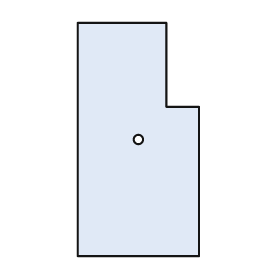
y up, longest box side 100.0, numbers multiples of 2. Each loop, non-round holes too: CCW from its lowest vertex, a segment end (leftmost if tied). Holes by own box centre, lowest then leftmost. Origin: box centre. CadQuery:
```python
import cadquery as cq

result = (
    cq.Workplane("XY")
    .moveTo(-26.0, -50.0)
    .lineTo(26.0, -50.0)
    .lineTo(26.0, 14.0)
    .lineTo(12.0, 14.0)
    .lineTo(12.0, 50.0)
    .lineTo(-26.0, 50.0)
    .close()
    .moveTo(0.0, 0.0)
    .circle(2.0)
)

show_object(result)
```